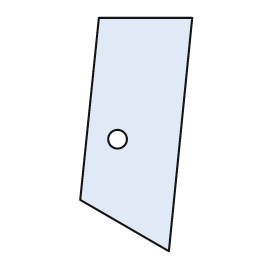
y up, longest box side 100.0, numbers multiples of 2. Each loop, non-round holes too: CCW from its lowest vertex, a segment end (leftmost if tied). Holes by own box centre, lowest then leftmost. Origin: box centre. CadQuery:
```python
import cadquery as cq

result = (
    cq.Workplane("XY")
    .moveTo(14.0, -50.0)
    .lineTo(24.0, 50.0)
    .lineTo(-16.0, 50.0)
    .lineTo(-24.0, -28.0)
    .close()
    .moveTo(-8.0, -2.0)
    .circle(4.0)
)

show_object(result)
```